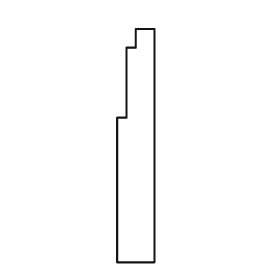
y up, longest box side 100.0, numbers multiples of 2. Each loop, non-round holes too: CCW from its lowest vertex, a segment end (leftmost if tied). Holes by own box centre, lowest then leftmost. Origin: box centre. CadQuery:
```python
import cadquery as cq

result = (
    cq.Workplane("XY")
    .moveTo(-8.0, -50.0)
    .lineTo(8.0, -50.0)
    .lineTo(8.0, 50.0)
    .lineTo(0.0, 50.0)
    .lineTo(0.0, 42.0)
    .lineTo(-4.0, 42.0)
    .lineTo(-4.0, 12.0)
    .lineTo(-8.0, 12.0)
    .close()
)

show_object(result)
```